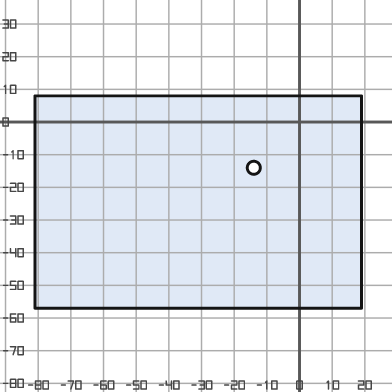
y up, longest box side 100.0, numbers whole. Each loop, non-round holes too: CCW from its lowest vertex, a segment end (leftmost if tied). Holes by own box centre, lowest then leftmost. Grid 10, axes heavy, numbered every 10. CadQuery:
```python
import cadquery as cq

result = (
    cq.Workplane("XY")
    .moveTo(-81.0, -57.0)
    .lineTo(19.0, -57.0)
    .lineTo(19.0, 8.0)
    .lineTo(-81.0, 8.0)
    .close()
    .moveTo(-14.0, -14.0)
    .circle(2.0)
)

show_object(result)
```